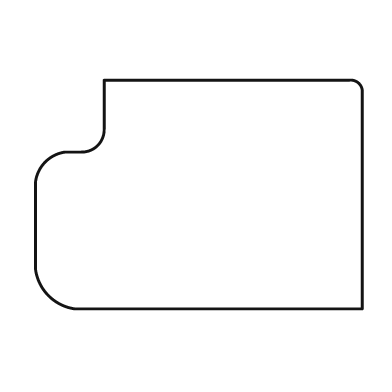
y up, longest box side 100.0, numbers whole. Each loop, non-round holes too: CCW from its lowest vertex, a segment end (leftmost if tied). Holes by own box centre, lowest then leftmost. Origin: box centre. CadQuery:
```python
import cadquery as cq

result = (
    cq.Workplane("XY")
    .moveTo(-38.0, -35.0)
    .lineTo(50.0, -35.0)
    .lineTo(50.0, 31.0)
    .threePointArc((49.0, 34.0), (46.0, 35.0))
    .lineTo(-29.0, 35.0)
    .lineTo(-29.0, 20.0)
    .threePointArc((-31.0, 15.0), (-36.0, 13.0))
    .lineTo(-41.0, 13.0)
    .threePointArc((-47.0, 10.0), (-50.0, 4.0))
    .lineTo(-50.0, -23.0)
    .threePointArc((-46.0, -31.0), (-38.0, -35.0))
    .close()
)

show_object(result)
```